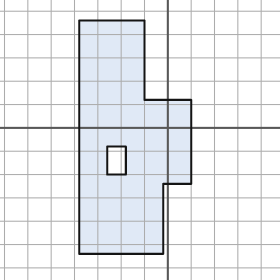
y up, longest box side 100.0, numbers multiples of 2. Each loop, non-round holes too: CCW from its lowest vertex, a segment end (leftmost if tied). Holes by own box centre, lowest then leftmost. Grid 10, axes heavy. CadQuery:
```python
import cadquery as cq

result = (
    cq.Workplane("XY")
    .moveTo(-38.0, -54.0)
    .lineTo(-2.0, -54.0)
    .lineTo(-2.0, -24.0)
    .lineTo(10.0, -24.0)
    .lineTo(10.0, 12.0)
    .lineTo(-10.0, 12.0)
    .lineTo(-10.0, 46.0)
    .lineTo(-38.0, 46.0)
    .close()
    .moveTo(-26.0, -20.0)
    .lineTo(-18.0, -20.0)
    .lineTo(-18.0, -8.0)
    .lineTo(-26.0, -8.0)
    .close()
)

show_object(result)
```